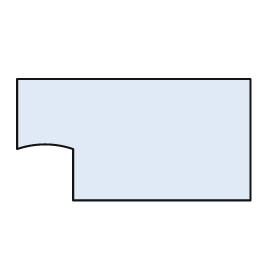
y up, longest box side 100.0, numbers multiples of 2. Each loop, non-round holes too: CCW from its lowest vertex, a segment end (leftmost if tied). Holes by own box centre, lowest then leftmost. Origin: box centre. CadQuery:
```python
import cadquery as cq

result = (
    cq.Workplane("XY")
    .moveTo(-26.0, -26.0)
    .lineTo(50.0, -26.0)
    .lineTo(50.0, 26.0)
    .lineTo(-50.0, 26.0)
    .lineTo(-50.0, -4.0)
    .threePointArc((-38.0, -2.0), (-26.0, -4.0))
    .close()
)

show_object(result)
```